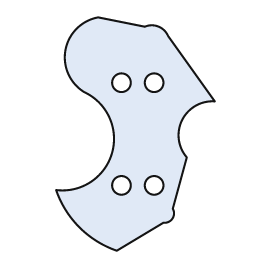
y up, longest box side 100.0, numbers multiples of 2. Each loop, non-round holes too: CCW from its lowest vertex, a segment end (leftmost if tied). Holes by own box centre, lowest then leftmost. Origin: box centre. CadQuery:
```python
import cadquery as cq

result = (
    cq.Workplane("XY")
    .moveTo(-8.0, -50.0)
    .lineTo(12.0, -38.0)
    .threePointArc((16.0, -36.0), (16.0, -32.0))
    .lineTo(22.0, -10.0)
    .threePointArc((20.0, 6.0), (34.0, 14.0))
    .lineTo(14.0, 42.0)
    .threePointArc((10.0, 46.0), (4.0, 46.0))
    .lineTo(-16.0, 50.0)
    .threePointArc((-30.0, 36.0), (-22.0, 18.0))
    .threePointArc((-10.0, -8.0), (-34.0, -24.0))
    .threePointArc((-24.0, -40.0), (-8.0, -50.0))
    .close()
    .moveTo(-6.0, -22.0)
    .circle(4.0)
    .moveTo(8.0, -22.0)
    .circle(4.0)
    .moveTo(-6.0, 22.0)
    .circle(4.0)
    .moveTo(8.0, 22.0)
    .circle(4.0)
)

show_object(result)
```